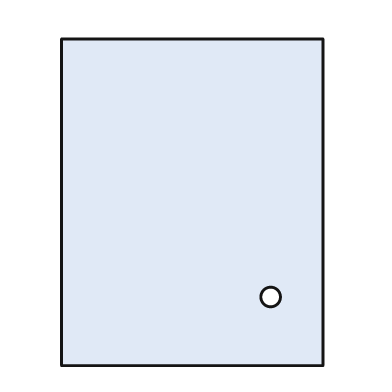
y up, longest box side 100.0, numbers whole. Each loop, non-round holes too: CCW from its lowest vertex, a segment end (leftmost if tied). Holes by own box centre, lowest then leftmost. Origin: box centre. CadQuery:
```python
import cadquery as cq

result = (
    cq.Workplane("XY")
    .moveTo(-40.0, -50.0)
    .lineTo(40.0, -50.0)
    .lineTo(40.0, 50.0)
    .lineTo(-40.0, 50.0)
    .close()
    .moveTo(24.0, -29.0)
    .circle(3.0)
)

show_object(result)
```